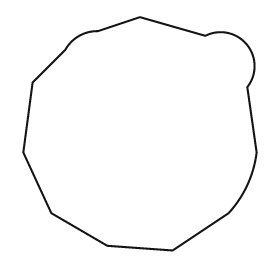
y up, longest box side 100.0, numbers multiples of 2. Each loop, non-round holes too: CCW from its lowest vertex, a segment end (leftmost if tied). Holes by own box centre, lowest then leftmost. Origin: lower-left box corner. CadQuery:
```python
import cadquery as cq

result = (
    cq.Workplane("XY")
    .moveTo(64.0, 0.0)
    .lineTo(88.0, 16.0)
    .threePointArc((96.0, 28.0), (100.0, 42.0))
    .lineTo(96.0, 70.0)
    .threePointArc((96.0, 88.0), (78.0, 92.0))
    .lineTo(50.0, 100.0)
    .lineTo(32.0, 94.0)
    .threePointArc((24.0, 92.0), (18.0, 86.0))
    .lineTo(4.0, 72.0)
    .lineTo(0.0, 42.0)
    .lineTo(12.0, 16.0)
    .lineTo(36.0, 2.0)
    .close()
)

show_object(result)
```